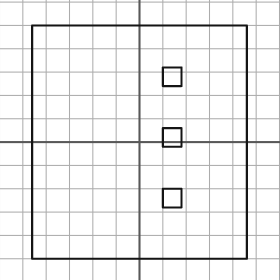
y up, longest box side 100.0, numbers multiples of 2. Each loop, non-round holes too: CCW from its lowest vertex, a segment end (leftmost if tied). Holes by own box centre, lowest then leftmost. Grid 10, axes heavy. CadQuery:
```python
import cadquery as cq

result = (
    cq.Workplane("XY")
    .moveTo(-46.0, -50.0)
    .lineTo(46.0, -50.0)
    .lineTo(46.0, 50.0)
    .lineTo(-46.0, 50.0)
    .close()
    .moveTo(10.0, -28.0)
    .lineTo(18.0, -28.0)
    .lineTo(18.0, -20.0)
    .lineTo(10.0, -20.0)
    .close()
    .moveTo(10.0, -2.0)
    .lineTo(18.0, -2.0)
    .lineTo(18.0, 6.0)
    .lineTo(10.0, 6.0)
    .close()
    .moveTo(10.0, 24.0)
    .lineTo(18.0, 24.0)
    .lineTo(18.0, 32.0)
    .lineTo(10.0, 32.0)
    .close()
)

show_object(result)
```